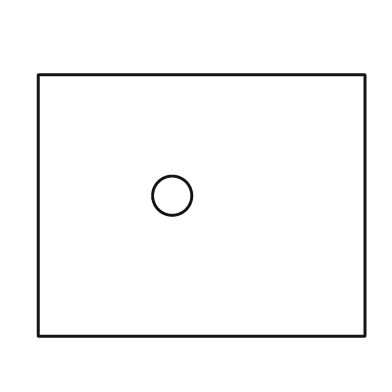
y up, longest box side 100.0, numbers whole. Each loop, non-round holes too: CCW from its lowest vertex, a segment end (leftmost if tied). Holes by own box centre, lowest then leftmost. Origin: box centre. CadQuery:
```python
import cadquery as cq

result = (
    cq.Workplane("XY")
    .moveTo(-50.0, -40.0)
    .lineTo(50.0, -40.0)
    .lineTo(50.0, 40.0)
    .lineTo(-50.0, 40.0)
    .close()
    .moveTo(-9.0, 3.0)
    .circle(6.0)
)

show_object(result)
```